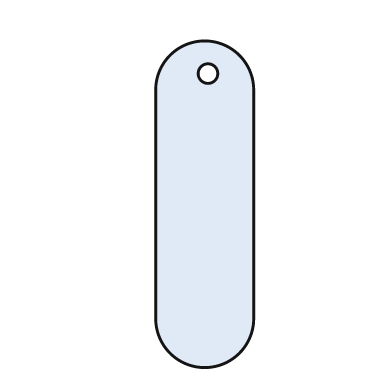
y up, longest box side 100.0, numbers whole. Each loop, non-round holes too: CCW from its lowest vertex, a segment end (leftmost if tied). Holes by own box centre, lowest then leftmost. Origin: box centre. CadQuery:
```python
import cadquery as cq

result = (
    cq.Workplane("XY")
    .moveTo(-15.0, -35.0)
    .threePointArc((0.0, -50.0), (15.0, -35.0))
    .lineTo(15.0, 35.0)
    .threePointArc((0.0, 50.0), (-15.0, 35.0))
    .close()
    .moveTo(1.0, 40.0)
    .circle(3.0)
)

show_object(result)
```